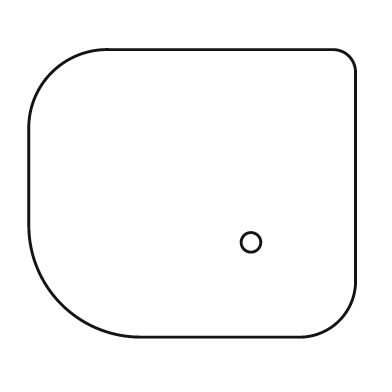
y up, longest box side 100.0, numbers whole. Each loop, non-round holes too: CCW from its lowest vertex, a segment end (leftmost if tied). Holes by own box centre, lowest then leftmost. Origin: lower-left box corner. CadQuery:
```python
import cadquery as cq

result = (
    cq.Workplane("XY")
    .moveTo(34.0, 0.0)
    .lineTo(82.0, 0.0)
    .threePointArc((95.0, 5.0), (100.0, 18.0))
    .lineTo(100.0, 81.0)
    .threePointArc((98.0, 86.0), (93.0, 88.0))
    .lineTo(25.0, 88.0)
    .threePointArc((7.0, 81.0), (0.0, 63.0))
    .lineTo(0.0, 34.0)
    .threePointArc((10.0, 10.0), (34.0, 0.0))
    .close()
    .moveTo(68.0, 29.0)
    .circle(3.0)
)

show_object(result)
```